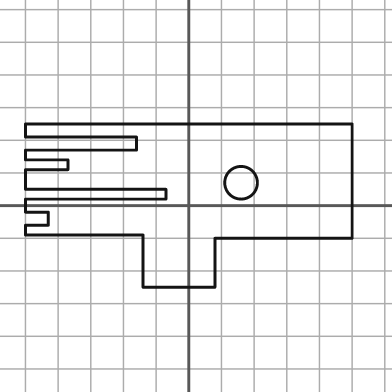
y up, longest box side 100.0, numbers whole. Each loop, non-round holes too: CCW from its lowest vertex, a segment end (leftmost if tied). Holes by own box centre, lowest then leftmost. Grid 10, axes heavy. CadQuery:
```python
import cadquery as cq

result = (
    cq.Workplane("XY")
    .moveTo(-14.0, -25.0)
    .lineTo(8.0, -25.0)
    .lineTo(8.0, -10.0)
    .lineTo(50.0, -10.0)
    .lineTo(50.0, 25.0)
    .lineTo(-50.0, 25.0)
    .lineTo(-50.0, 21.0)
    .lineTo(-16.0, 21.0)
    .lineTo(-16.0, 17.0)
    .lineTo(-50.0, 17.0)
    .lineTo(-50.0, 14.0)
    .lineTo(-37.0, 14.0)
    .lineTo(-37.0, 11.0)
    .lineTo(-50.0, 11.0)
    .lineTo(-50.0, 5.0)
    .lineTo(-7.0, 5.0)
    .lineTo(-7.0, 2.0)
    .lineTo(-50.0, 2.0)
    .lineTo(-50.0, -2.0)
    .lineTo(-43.0, -2.0)
    .lineTo(-43.0, -6.0)
    .lineTo(-50.0, -6.0)
    .lineTo(-50.0, -9.0)
    .lineTo(-14.0, -9.0)
    .close()
    .moveTo(16.0, 7.0)
    .circle(5.0)
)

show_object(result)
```